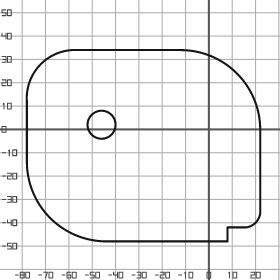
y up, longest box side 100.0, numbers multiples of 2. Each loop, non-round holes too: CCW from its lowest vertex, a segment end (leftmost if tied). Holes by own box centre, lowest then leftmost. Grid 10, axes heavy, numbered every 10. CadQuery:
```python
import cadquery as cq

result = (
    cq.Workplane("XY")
    .moveTo(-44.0, -48.0)
    .lineTo(8.0, -48.0)
    .lineTo(8.0, -42.0)
    .lineTo(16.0, -42.0)
    .threePointArc((20.0, -40.0), (22.0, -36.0))
    .lineTo(22.0, 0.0)
    .threePointArc((12.0, 24.0), (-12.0, 34.0))
    .lineTo(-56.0, 34.0)
    .threePointArc((-72.0, 28.0), (-78.0, 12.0))
    .lineTo(-78.0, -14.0)
    .threePointArc((-68.0, -38.0), (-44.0, -48.0))
    .close()
    .moveTo(-46.0, 2.0)
    .circle(6.0)
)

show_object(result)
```